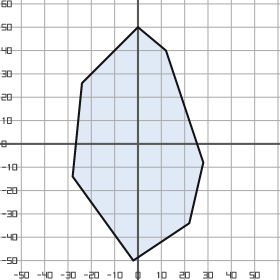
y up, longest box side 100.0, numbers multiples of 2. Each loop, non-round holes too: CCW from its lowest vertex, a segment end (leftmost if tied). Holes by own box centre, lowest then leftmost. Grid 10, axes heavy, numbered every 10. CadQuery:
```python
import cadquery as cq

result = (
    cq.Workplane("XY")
    .moveTo(-2.0, -50.0)
    .lineTo(22.0, -34.0)
    .lineTo(28.0, -8.0)
    .lineTo(12.0, 40.0)
    .lineTo(0.0, 50.0)
    .lineTo(-24.0, 26.0)
    .lineTo(-28.0, -14.0)
    .close()
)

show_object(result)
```